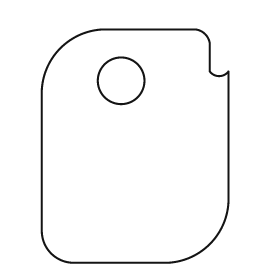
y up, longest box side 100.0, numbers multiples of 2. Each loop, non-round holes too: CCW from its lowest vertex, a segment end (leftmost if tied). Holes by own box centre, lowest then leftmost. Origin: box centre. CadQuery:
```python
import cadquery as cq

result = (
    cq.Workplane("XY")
    .moveTo(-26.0, -50.0)
    .lineTo(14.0, -50.0)
    .threePointArc((32.0, -42.0), (40.0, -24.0))
    .lineTo(40.0, 32.0)
    .threePointArc((36.0, 30.0), (32.0, 32.0))
    .lineTo(32.0, 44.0)
    .threePointArc((30.0, 48.0), (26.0, 50.0))
    .lineTo(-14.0, 50.0)
    .threePointArc((-32.0, 42.0), (-40.0, 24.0))
    .lineTo(-40.0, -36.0)
    .threePointArc((-36.0, -46.0), (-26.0, -50.0))
    .close()
    .moveTo(-6.0, 28.0)
    .circle(10.0)
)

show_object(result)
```